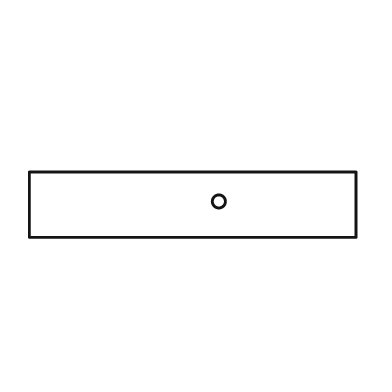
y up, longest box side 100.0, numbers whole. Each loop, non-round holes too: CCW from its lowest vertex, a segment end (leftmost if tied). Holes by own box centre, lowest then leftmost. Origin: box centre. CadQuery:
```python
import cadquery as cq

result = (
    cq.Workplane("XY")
    .moveTo(-50.0, -10.0)
    .lineTo(50.0, -10.0)
    .lineTo(50.0, 10.0)
    .lineTo(-50.0, 10.0)
    .close()
    .moveTo(8.0, 1.0)
    .circle(2.0)
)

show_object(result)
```